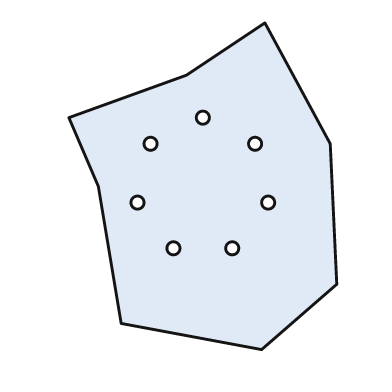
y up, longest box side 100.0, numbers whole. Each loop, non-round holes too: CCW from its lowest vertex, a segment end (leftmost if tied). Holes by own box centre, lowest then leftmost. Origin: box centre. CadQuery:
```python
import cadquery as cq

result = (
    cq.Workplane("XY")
    .moveTo(18.0, -50.0)
    .lineTo(41.0, -30.0)
    .lineTo(39.0, 13.0)
    .lineTo(19.0, 50.0)
    .lineTo(-5.0, 34.0)
    .lineTo(-41.0, 21.0)
    .lineTo(-32.0, 0.0)
    .lineTo(-25.0, -42.0)
    .close()
    .moveTo(-9.0, -19.0)
    .circle(2.0)
    .moveTo(9.0, -19.0)
    .circle(2.0)
    .moveTo(-20.0, -5.0)
    .circle(2.0)
    .moveTo(20.0, -5.0)
    .circle(2.0)
    .moveTo(-16.0, 13.0)
    .circle(2.0)
    .moveTo(16.0, 13.0)
    .circle(2.0)
    .moveTo(0.0, 21.0)
    .circle(2.0)
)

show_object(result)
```